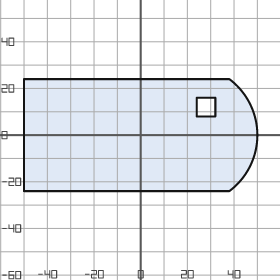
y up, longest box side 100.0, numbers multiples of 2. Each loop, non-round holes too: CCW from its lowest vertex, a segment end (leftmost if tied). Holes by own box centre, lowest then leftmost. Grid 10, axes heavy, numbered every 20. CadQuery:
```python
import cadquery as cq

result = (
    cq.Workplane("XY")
    .moveTo(-50.0, -24.0)
    .lineTo(38.0, -24.0)
    .threePointArc((50.0, 0.0), (38.0, 24.0))
    .lineTo(-50.0, 24.0)
    .close()
    .moveTo(24.0, 8.0)
    .lineTo(32.0, 8.0)
    .lineTo(32.0, 16.0)
    .lineTo(24.0, 16.0)
    .close()
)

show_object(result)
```